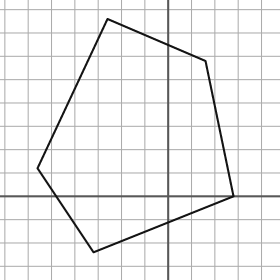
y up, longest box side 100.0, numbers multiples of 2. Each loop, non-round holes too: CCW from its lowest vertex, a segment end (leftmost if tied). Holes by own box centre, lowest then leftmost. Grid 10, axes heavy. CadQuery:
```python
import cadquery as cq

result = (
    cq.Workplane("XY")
    .moveTo(-32.0, -24.0)
    .lineTo(28.0, 0.0)
    .lineTo(16.0, 58.0)
    .lineTo(-26.0, 76.0)
    .lineTo(-56.0, 12.0)
    .close()
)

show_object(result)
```